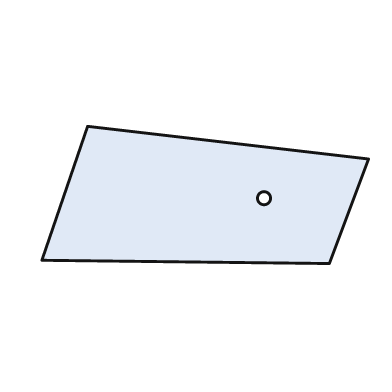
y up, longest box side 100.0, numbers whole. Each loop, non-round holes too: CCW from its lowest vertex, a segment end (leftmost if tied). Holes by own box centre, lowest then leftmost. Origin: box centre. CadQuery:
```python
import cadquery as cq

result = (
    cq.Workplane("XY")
    .moveTo(38.0, -21.0)
    .lineTo(50.0, 11.0)
    .lineTo(-36.0, 21.0)
    .lineTo(-50.0, -20.0)
    .close()
    .moveTo(18.0, -1.0)
    .circle(2.0)
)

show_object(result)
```